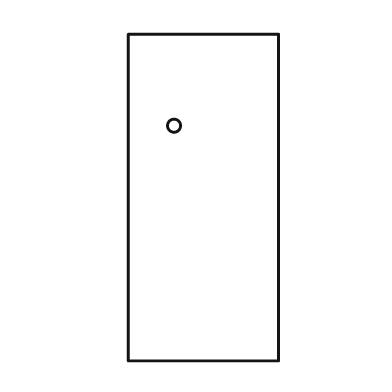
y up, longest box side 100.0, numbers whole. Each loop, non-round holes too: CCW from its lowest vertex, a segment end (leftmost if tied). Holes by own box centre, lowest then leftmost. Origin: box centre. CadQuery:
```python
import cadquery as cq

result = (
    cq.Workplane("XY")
    .moveTo(-23.0, -50.0)
    .lineTo(23.0, -50.0)
    .lineTo(23.0, 50.0)
    .lineTo(-23.0, 50.0)
    .close()
    .moveTo(-9.0, 22.0)
    .circle(2.0)
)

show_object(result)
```